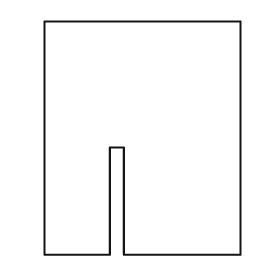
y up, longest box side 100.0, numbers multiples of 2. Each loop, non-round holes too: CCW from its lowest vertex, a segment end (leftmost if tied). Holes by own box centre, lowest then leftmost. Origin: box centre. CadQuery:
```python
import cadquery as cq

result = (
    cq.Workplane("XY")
    .moveTo(-42.0, -50.0)
    .lineTo(-14.0, -50.0)
    .lineTo(-14.0, -4.0)
    .lineTo(-8.0, -4.0)
    .lineTo(-8.0, -50.0)
    .lineTo(42.0, -50.0)
    .lineTo(42.0, 50.0)
    .lineTo(-42.0, 50.0)
    .close()
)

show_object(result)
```